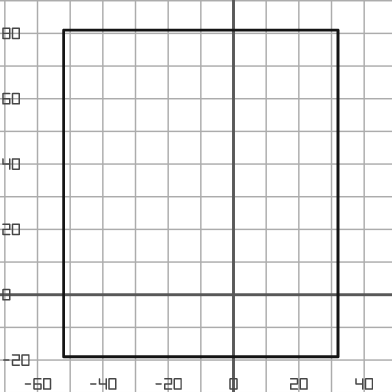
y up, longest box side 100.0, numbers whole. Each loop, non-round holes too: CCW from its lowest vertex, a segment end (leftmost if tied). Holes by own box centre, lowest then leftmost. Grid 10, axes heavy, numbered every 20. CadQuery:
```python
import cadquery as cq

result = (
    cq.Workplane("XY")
    .moveTo(-52.0, -19.0)
    .lineTo(32.0, -19.0)
    .lineTo(32.0, 81.0)
    .lineTo(-52.0, 81.0)
    .close()
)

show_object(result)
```